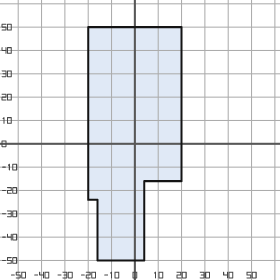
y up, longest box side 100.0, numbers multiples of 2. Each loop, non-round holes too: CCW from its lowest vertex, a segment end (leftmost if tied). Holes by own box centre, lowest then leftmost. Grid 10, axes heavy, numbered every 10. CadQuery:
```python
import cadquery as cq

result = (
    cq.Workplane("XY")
    .moveTo(-16.0, -50.0)
    .lineTo(4.0, -50.0)
    .lineTo(4.0, -16.0)
    .lineTo(20.0, -16.0)
    .lineTo(20.0, 50.0)
    .lineTo(-20.0, 50.0)
    .lineTo(-20.0, -24.0)
    .lineTo(-16.0, -24.0)
    .close()
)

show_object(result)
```